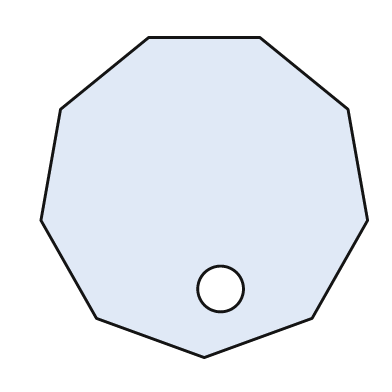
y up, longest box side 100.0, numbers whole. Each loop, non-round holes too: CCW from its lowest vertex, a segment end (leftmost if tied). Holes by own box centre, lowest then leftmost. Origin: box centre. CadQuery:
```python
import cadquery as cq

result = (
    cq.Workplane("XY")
    .moveTo(0.0, -49.0)
    .lineTo(33.0, -37.0)
    .lineTo(50.0, -7.0)
    .lineTo(44.0, 27.0)
    .lineTo(17.0, 49.0)
    .lineTo(-17.0, 49.0)
    .lineTo(-44.0, 27.0)
    .lineTo(-50.0, -7.0)
    .lineTo(-33.0, -37.0)
    .close()
    .moveTo(5.0, -28.0)
    .circle(7.0)
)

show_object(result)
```